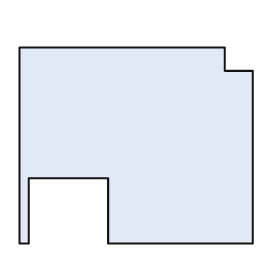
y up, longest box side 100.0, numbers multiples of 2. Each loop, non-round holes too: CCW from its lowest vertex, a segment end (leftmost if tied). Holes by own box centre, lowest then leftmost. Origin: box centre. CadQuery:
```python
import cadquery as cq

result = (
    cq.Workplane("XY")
    .moveTo(-50.0, -42.0)
    .lineTo(-46.0, -42.0)
    .lineTo(-46.0, -14.0)
    .lineTo(-12.0, -14.0)
    .lineTo(-12.0, -42.0)
    .lineTo(50.0, -42.0)
    .lineTo(50.0, 32.0)
    .lineTo(38.0, 32.0)
    .lineTo(38.0, 42.0)
    .lineTo(-50.0, 42.0)
    .close()
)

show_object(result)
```